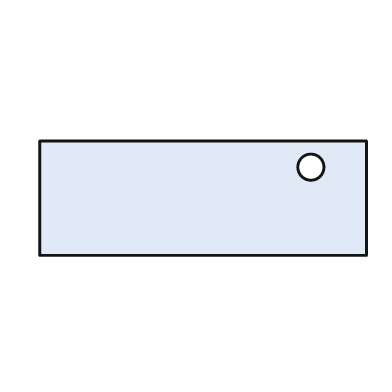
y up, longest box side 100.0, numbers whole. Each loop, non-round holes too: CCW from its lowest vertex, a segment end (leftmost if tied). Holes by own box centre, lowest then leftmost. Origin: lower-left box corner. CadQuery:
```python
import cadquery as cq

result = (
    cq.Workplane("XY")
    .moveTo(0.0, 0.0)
    .lineTo(100.0, 0.0)
    .lineTo(100.0, 35.0)
    .lineTo(0.0, 35.0)
    .close()
    .moveTo(83.0, 27.0)
    .circle(4.0)
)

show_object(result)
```